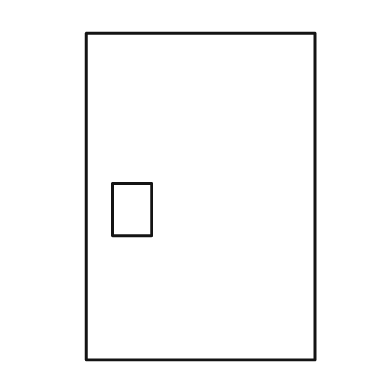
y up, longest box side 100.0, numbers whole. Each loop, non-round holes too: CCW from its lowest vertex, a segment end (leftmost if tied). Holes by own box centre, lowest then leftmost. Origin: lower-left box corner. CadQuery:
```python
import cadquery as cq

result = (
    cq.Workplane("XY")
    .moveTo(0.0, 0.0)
    .lineTo(70.0, 0.0)
    .lineTo(70.0, 100.0)
    .lineTo(0.0, 100.0)
    .close()
    .moveTo(8.0, 38.0)
    .lineTo(20.0, 38.0)
    .lineTo(20.0, 54.0)
    .lineTo(8.0, 54.0)
    .close()
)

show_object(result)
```